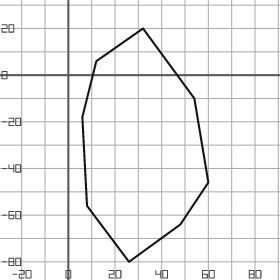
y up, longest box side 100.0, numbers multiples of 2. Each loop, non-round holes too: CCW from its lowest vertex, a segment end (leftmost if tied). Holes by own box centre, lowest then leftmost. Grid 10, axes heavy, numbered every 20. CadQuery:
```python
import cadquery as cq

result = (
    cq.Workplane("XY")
    .moveTo(26.0, -80.0)
    .lineTo(48.0, -64.0)
    .lineTo(60.0, -46.0)
    .lineTo(54.0, -10.0)
    .lineTo(32.0, 20.0)
    .lineTo(12.0, 6.0)
    .lineTo(6.0, -18.0)
    .lineTo(8.0, -56.0)
    .close()
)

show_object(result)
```